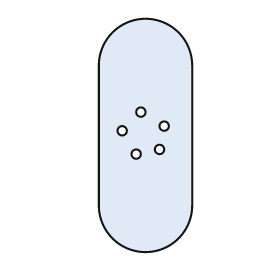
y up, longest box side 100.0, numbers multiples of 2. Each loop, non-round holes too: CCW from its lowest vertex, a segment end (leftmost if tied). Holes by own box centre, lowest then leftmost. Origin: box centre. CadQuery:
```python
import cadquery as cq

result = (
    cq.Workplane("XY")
    .moveTo(-20.0, -30.0)
    .threePointArc((0.0, -50.0), (20.0, -30.0))
    .lineTo(20.0, 30.0)
    .threePointArc((0.0, 50.0), (-20.0, 30.0))
    .close()
    .moveTo(-4.0, -8.0)
    .circle(2.0)
    .moveTo(6.0, -6.0)
    .circle(2.0)
    .moveTo(-10.0, 2.0)
    .circle(2.0)
    .moveTo(8.0, 4.0)
    .circle(2.0)
    .moveTo(-2.0, 10.0)
    .circle(2.0)
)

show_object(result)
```